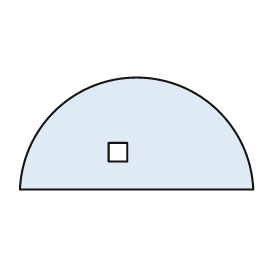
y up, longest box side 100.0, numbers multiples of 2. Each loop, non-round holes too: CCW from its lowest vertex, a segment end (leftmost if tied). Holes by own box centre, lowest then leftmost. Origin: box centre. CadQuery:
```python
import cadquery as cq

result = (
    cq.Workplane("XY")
    .moveTo(-50.0, -24.0)
    .lineTo(50.0, -24.0)
    .threePointArc((0.0, 24.0), (-50.0, -24.0))
    .close()
    .moveTo(-12.0, -12.0)
    .lineTo(-4.0, -12.0)
    .lineTo(-4.0, -4.0)
    .lineTo(-12.0, -4.0)
    .close()
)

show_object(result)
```